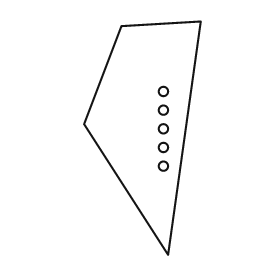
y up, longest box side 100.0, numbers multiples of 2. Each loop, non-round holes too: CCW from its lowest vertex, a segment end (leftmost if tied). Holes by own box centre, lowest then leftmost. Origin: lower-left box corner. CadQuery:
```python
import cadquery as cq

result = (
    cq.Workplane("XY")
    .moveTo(36.0, 0.0)
    .lineTo(50.0, 100.0)
    .lineTo(16.0, 98.0)
    .lineTo(0.0, 56.0)
    .close()
    .moveTo(34.0, 38.0)
    .circle(2.0)
    .moveTo(34.0, 46.0)
    .circle(2.0)
    .moveTo(34.0, 54.0)
    .circle(2.0)
    .moveTo(34.0, 62.0)
    .circle(2.0)
    .moveTo(34.0, 70.0)
    .circle(2.0)
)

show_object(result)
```